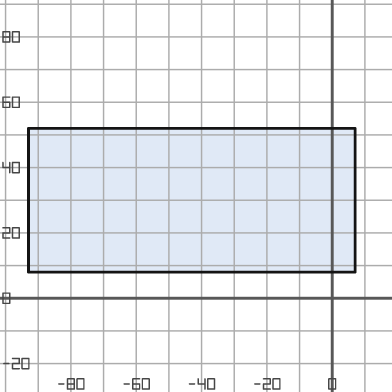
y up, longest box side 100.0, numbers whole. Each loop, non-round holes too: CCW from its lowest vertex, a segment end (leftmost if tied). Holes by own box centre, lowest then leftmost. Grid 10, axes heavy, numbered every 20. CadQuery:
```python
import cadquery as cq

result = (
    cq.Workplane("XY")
    .moveTo(-93.0, 8.0)
    .lineTo(7.0, 8.0)
    .lineTo(7.0, 52.0)
    .lineTo(-93.0, 52.0)
    .close()
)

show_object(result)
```